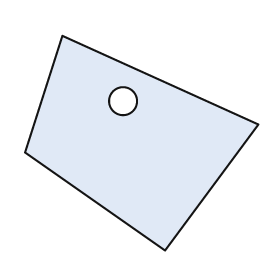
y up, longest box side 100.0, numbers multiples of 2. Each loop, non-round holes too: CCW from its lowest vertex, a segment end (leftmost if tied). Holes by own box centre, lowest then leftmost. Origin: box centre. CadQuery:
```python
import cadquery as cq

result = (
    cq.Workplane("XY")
    .moveTo(10.0, -46.0)
    .lineTo(50.0, 8.0)
    .lineTo(-34.0, 46.0)
    .lineTo(-50.0, -4.0)
    .close()
    .moveTo(-8.0, 18.0)
    .circle(6.0)
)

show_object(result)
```